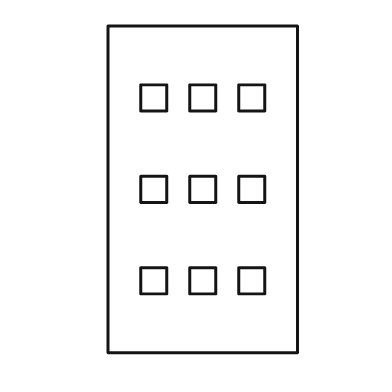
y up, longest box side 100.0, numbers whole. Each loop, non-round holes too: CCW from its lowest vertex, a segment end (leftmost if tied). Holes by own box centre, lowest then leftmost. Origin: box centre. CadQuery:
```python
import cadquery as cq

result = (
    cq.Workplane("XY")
    .moveTo(-29.0, -50.0)
    .lineTo(29.0, -50.0)
    .lineTo(29.0, 50.0)
    .lineTo(-29.0, 50.0)
    .close()
    .moveTo(-19.0, -32.0)
    .lineTo(-11.0, -32.0)
    .lineTo(-11.0, -24.0)
    .lineTo(-19.0, -24.0)
    .close()
    .moveTo(-4.0, -32.0)
    .lineTo(4.0, -32.0)
    .lineTo(4.0, -24.0)
    .lineTo(-4.0, -24.0)
    .close()
    .moveTo(11.0, -32.0)
    .lineTo(19.0, -32.0)
    .lineTo(19.0, -24.0)
    .lineTo(11.0, -24.0)
    .close()
    .moveTo(-19.0, -4.0)
    .lineTo(-11.0, -4.0)
    .lineTo(-11.0, 4.0)
    .lineTo(-19.0, 4.0)
    .close()
    .moveTo(-4.0, -4.0)
    .lineTo(4.0, -4.0)
    .lineTo(4.0, 4.0)
    .lineTo(-4.0, 4.0)
    .close()
    .moveTo(11.0, -4.0)
    .lineTo(19.0, -4.0)
    .lineTo(19.0, 4.0)
    .lineTo(11.0, 4.0)
    .close()
    .moveTo(-19.0, 24.0)
    .lineTo(-11.0, 24.0)
    .lineTo(-11.0, 32.0)
    .lineTo(-19.0, 32.0)
    .close()
    .moveTo(-4.0, 24.0)
    .lineTo(4.0, 24.0)
    .lineTo(4.0, 32.0)
    .lineTo(-4.0, 32.0)
    .close()
    .moveTo(11.0, 24.0)
    .lineTo(19.0, 24.0)
    .lineTo(19.0, 32.0)
    .lineTo(11.0, 32.0)
    .close()
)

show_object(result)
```